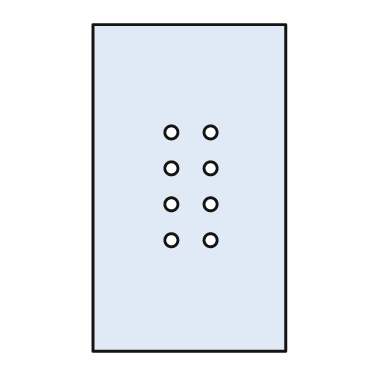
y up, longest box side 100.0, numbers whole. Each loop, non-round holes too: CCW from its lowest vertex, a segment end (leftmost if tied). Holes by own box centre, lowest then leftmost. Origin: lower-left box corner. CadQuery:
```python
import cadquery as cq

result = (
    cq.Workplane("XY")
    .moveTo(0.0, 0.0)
    .lineTo(59.0, 0.0)
    .lineTo(59.0, 100.0)
    .lineTo(0.0, 100.0)
    .close()
    .moveTo(24.0, 34.0)
    .circle(2.0)
    .moveTo(36.0, 34.0)
    .circle(2.0)
    .moveTo(24.0, 45.0)
    .circle(2.0)
    .moveTo(36.0, 45.0)
    .circle(2.0)
    .moveTo(24.0, 56.0)
    .circle(2.0)
    .moveTo(36.0, 56.0)
    .circle(2.0)
    .moveTo(24.0, 67.0)
    .circle(2.0)
    .moveTo(36.0, 67.0)
    .circle(2.0)
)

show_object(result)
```